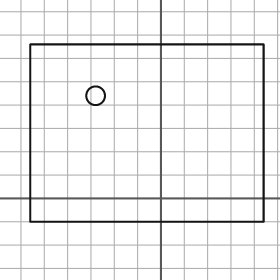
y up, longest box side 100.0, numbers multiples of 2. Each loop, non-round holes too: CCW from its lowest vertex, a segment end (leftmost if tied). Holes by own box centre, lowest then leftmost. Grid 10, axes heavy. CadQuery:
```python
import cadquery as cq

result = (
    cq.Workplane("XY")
    .moveTo(-56.0, -10.0)
    .lineTo(44.0, -10.0)
    .lineTo(44.0, 66.0)
    .lineTo(-56.0, 66.0)
    .close()
    .moveTo(-28.0, 44.0)
    .circle(4.0)
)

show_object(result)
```